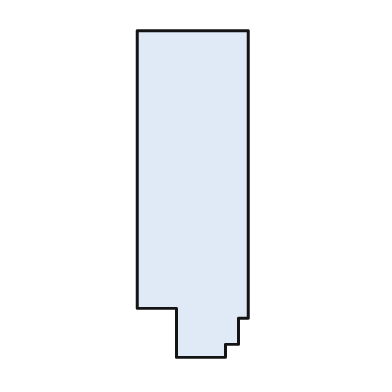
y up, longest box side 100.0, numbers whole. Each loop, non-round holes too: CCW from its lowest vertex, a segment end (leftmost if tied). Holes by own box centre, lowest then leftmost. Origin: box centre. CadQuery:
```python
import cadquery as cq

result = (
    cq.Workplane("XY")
    .moveTo(-5.0, -50.0)
    .lineTo(10.0, -50.0)
    .lineTo(10.0, -46.0)
    .lineTo(14.0, -46.0)
    .lineTo(14.0, -38.0)
    .lineTo(17.0, -38.0)
    .lineTo(17.0, 50.0)
    .lineTo(-17.0, 50.0)
    .lineTo(-17.0, -35.0)
    .lineTo(-5.0, -35.0)
    .close()
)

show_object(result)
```